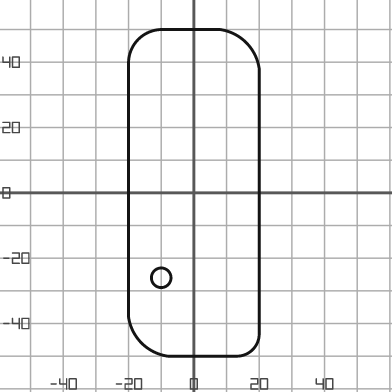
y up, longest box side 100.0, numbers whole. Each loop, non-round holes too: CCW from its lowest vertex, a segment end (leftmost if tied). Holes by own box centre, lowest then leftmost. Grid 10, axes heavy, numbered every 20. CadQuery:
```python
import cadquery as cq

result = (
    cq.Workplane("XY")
    .moveTo(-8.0, -50.0)
    .lineTo(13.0, -50.0)
    .threePointArc((18.0, -48.0), (20.0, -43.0))
    .lineTo(20.0, 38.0)
    .threePointArc((16.0, 46.0), (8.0, 50.0))
    .lineTo(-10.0, 50.0)
    .threePointArc((-17.0, 47.0), (-20.0, 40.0))
    .lineTo(-20.0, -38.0)
    .threePointArc((-16.0, -46.0), (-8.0, -50.0))
    .close()
    .moveTo(-10.0, -26.0)
    .circle(3.0)
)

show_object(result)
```